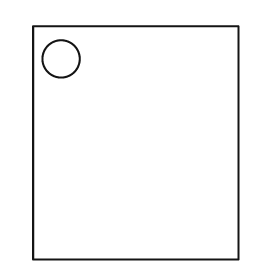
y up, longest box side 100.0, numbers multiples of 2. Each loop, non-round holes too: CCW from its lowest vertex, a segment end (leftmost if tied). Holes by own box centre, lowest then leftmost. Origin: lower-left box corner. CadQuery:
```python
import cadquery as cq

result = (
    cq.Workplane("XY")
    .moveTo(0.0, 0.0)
    .lineTo(88.0, 0.0)
    .lineTo(88.0, 100.0)
    .lineTo(0.0, 100.0)
    .close()
    .moveTo(12.0, 86.0)
    .circle(8.0)
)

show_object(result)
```